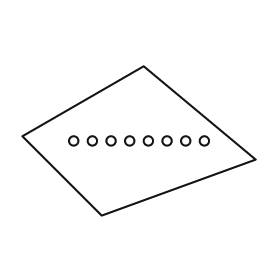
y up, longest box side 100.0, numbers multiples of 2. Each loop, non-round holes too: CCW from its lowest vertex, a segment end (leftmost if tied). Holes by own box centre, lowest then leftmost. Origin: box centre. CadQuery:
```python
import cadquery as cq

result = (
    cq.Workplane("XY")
    .moveTo(-16.0, -32.0)
    .lineTo(50.0, -8.0)
    .lineTo(2.0, 32.0)
    .lineTo(-50.0, 2.0)
    .close()
    .moveTo(-28.0, 0.0)
    .circle(2.0)
    .moveTo(-20.0, 0.0)
    .circle(2.0)
    .moveTo(-12.0, 0.0)
    .circle(2.0)
    .moveTo(-4.0, 0.0)
    .circle(2.0)
    .moveTo(4.0, 0.0)
    .circle(2.0)
    .moveTo(12.0, 0.0)
    .circle(2.0)
    .moveTo(20.0, 0.0)
    .circle(2.0)
    .moveTo(28.0, 0.0)
    .circle(2.0)
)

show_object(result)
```